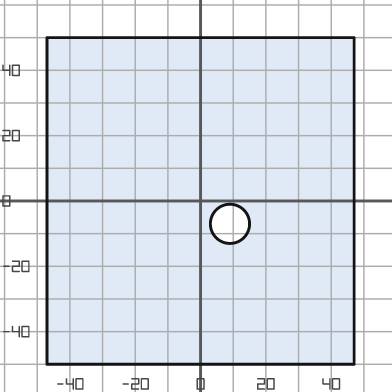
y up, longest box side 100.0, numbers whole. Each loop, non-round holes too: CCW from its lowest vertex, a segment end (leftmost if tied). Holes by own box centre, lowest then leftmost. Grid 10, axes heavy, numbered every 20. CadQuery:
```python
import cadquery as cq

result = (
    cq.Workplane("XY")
    .moveTo(-47.0, -50.0)
    .lineTo(47.0, -50.0)
    .lineTo(47.0, 50.0)
    .lineTo(-47.0, 50.0)
    .close()
    .moveTo(9.0, -7.0)
    .circle(6.0)
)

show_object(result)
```